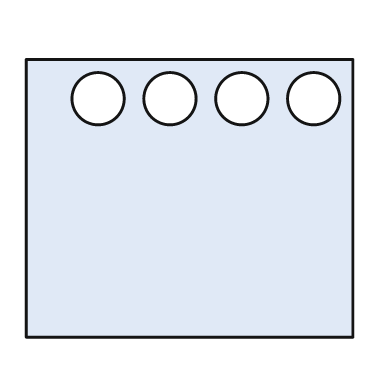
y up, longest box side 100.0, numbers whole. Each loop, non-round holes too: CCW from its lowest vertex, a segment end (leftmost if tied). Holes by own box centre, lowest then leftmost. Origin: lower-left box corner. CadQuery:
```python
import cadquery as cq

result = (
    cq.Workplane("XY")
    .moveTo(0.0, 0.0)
    .lineTo(100.0, 0.0)
    .lineTo(100.0, 85.0)
    .lineTo(0.0, 85.0)
    .close()
    .moveTo(22.0, 73.0)
    .circle(8.0)
    .moveTo(44.0, 73.0)
    .circle(8.0)
    .moveTo(66.0, 73.0)
    .circle(8.0)
    .moveTo(88.0, 73.0)
    .circle(8.0)
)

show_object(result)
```